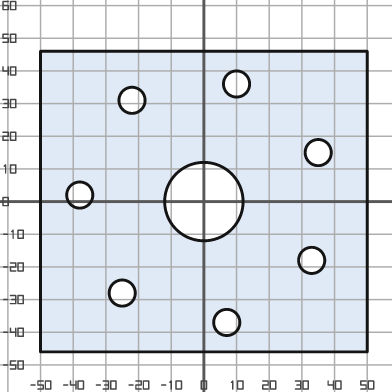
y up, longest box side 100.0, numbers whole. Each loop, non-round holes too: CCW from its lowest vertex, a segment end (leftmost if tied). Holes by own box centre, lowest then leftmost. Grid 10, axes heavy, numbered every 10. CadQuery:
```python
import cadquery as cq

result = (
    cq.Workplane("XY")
    .moveTo(-50.0, -46.0)
    .lineTo(50.0, -46.0)
    .lineTo(50.0, 46.0)
    .lineTo(-50.0, 46.0)
    .close()
    .moveTo(7.0, -37.0)
    .circle(4.0)
    .moveTo(-25.0, -28.0)
    .circle(4.0)
    .moveTo(33.0, -18.0)
    .circle(4.0)
    .moveTo(0.0, 0.0)
    .circle(12.0)
    .moveTo(-38.0, 2.0)
    .circle(4.0)
    .moveTo(35.0, 15.0)
    .circle(4.0)
    .moveTo(-22.0, 31.0)
    .circle(4.0)
    .moveTo(10.0, 36.0)
    .circle(4.0)
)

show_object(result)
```